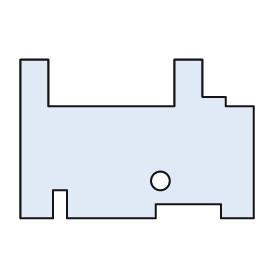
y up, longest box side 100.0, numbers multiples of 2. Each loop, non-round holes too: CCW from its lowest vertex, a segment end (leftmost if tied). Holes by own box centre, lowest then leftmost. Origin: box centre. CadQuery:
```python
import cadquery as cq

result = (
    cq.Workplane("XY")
    .moveTo(-50.0, -34.0)
    .lineTo(-36.0, -34.0)
    .lineTo(-36.0, -22.0)
    .lineTo(-30.0, -22.0)
    .lineTo(-30.0, -34.0)
    .lineTo(8.0, -34.0)
    .lineTo(8.0, -28.0)
    .lineTo(36.0, -28.0)
    .lineTo(36.0, -34.0)
    .lineTo(50.0, -34.0)
    .lineTo(50.0, 14.0)
    .lineTo(38.0, 14.0)
    .lineTo(38.0, 18.0)
    .lineTo(28.0, 18.0)
    .lineTo(28.0, 34.0)
    .lineTo(16.0, 34.0)
    .lineTo(16.0, 14.0)
    .lineTo(-38.0, 14.0)
    .lineTo(-38.0, 34.0)
    .lineTo(-50.0, 34.0)
    .close()
    .moveTo(10.0, -18.0)
    .circle(4.0)
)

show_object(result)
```